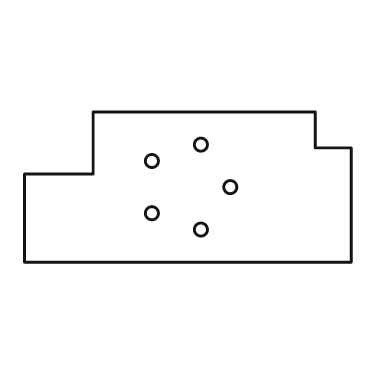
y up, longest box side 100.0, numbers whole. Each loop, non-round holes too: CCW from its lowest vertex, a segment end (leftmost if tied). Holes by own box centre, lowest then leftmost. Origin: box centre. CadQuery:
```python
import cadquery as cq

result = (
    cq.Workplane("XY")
    .moveTo(-50.0, -23.0)
    .lineTo(50.0, -23.0)
    .lineTo(50.0, 12.0)
    .lineTo(39.0, 12.0)
    .lineTo(39.0, 23.0)
    .lineTo(-29.0, 23.0)
    .lineTo(-29.0, 4.0)
    .lineTo(-50.0, 4.0)
    .close()
    .moveTo(4.0, -13.0)
    .circle(2.0)
    .moveTo(-11.0, -8.0)
    .circle(2.0)
    .moveTo(13.0, 0.0)
    .circle(2.0)
    .moveTo(-11.0, 8.0)
    .circle(2.0)
    .moveTo(4.0, 13.0)
    .circle(2.0)
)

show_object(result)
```